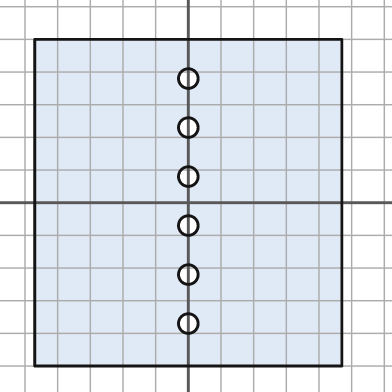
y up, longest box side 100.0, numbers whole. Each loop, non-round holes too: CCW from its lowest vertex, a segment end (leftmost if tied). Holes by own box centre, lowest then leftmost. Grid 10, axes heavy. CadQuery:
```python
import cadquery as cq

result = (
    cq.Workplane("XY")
    .moveTo(-47.0, -50.0)
    .lineTo(47.0, -50.0)
    .lineTo(47.0, 50.0)
    .lineTo(-47.0, 50.0)
    .close()
    .moveTo(0.0, -37.0)
    .circle(3.0)
    .moveTo(0.0, -22.0)
    .circle(3.0)
    .moveTo(0.0, -7.0)
    .circle(3.0)
    .moveTo(0.0, 8.0)
    .circle(3.0)
    .moveTo(0.0, 23.0)
    .circle(3.0)
    .moveTo(0.0, 38.0)
    .circle(3.0)
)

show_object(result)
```